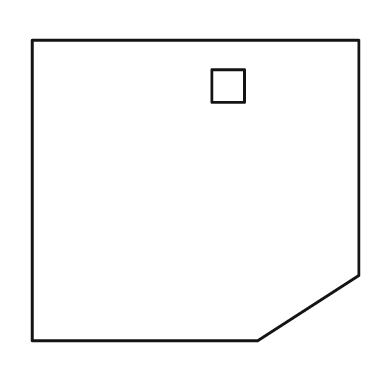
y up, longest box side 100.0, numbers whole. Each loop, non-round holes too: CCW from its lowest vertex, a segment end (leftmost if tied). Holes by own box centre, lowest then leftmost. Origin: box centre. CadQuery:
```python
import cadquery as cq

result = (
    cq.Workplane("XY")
    .moveTo(-50.0, -46.0)
    .lineTo(19.0, -46.0)
    .lineTo(50.0, -26.0)
    .lineTo(50.0, 46.0)
    .lineTo(-50.0, 46.0)
    .close()
    .moveTo(5.0, 27.0)
    .lineTo(15.0, 27.0)
    .lineTo(15.0, 37.0)
    .lineTo(5.0, 37.0)
    .close()
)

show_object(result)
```